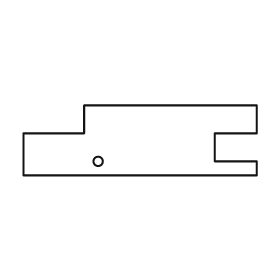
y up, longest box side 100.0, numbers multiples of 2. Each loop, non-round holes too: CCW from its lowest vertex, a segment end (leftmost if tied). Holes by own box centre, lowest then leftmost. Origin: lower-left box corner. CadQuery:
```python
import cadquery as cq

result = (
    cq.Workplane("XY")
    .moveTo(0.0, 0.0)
    .lineTo(100.0, 0.0)
    .lineTo(100.0, 6.0)
    .lineTo(82.0, 6.0)
    .lineTo(82.0, 18.0)
    .lineTo(100.0, 18.0)
    .lineTo(100.0, 30.0)
    .lineTo(26.0, 30.0)
    .lineTo(26.0, 18.0)
    .lineTo(0.0, 18.0)
    .close()
    .moveTo(32.0, 6.0)
    .circle(2.0)
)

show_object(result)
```